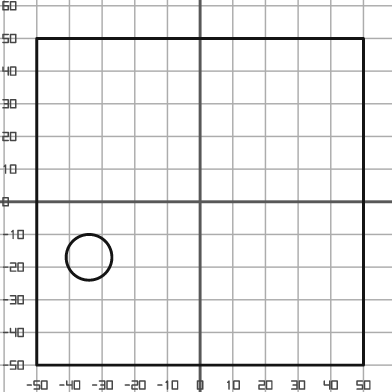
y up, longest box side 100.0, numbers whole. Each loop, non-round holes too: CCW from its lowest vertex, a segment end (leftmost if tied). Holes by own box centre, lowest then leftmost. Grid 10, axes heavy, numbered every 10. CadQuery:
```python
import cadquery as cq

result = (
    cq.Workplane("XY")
    .moveTo(-50.0, -50.0)
    .lineTo(50.0, -50.0)
    .lineTo(50.0, 50.0)
    .lineTo(-50.0, 50.0)
    .close()
    .moveTo(-34.0, -17.0)
    .circle(7.0)
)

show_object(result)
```